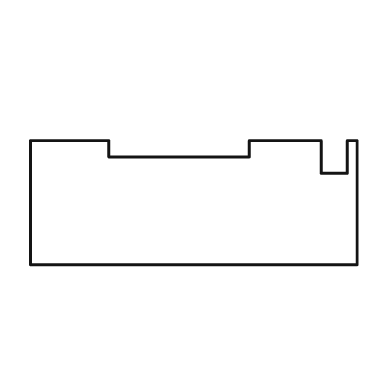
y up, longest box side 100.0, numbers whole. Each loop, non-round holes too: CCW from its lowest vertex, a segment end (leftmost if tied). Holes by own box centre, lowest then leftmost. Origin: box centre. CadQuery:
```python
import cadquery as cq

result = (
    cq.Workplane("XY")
    .moveTo(-50.0, -19.0)
    .lineTo(50.0, -19.0)
    .lineTo(50.0, 19.0)
    .lineTo(47.0, 19.0)
    .lineTo(47.0, 9.0)
    .lineTo(39.0, 9.0)
    .lineTo(39.0, 19.0)
    .lineTo(17.0, 19.0)
    .lineTo(17.0, 14.0)
    .lineTo(-26.0, 14.0)
    .lineTo(-26.0, 19.0)
    .lineTo(-50.0, 19.0)
    .close()
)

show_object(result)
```